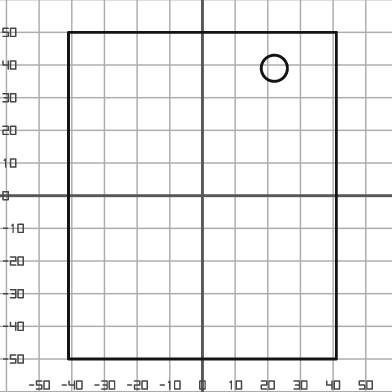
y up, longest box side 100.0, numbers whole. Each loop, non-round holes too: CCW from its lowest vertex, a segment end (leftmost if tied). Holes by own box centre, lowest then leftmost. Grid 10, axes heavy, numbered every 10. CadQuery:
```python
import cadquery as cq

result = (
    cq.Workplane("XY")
    .moveTo(-41.0, -50.0)
    .lineTo(41.0, -50.0)
    .lineTo(41.0, 50.0)
    .lineTo(-41.0, 50.0)
    .close()
    .moveTo(22.0, 39.0)
    .circle(4.0)
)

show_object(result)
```